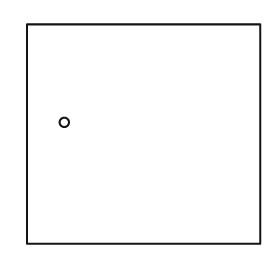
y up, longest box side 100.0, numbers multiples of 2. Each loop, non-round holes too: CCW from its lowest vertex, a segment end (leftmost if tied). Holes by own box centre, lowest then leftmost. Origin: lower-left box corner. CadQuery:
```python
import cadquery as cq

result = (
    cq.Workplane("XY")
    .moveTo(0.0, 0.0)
    .lineTo(100.0, 0.0)
    .lineTo(100.0, 94.0)
    .lineTo(0.0, 94.0)
    .close()
    .moveTo(16.0, 52.0)
    .circle(2.0)
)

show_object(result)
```